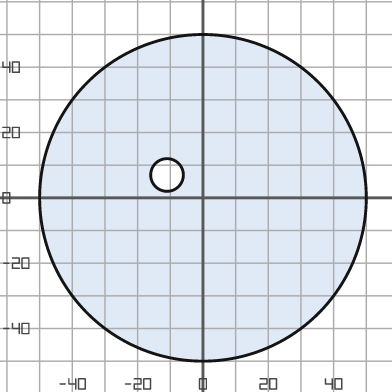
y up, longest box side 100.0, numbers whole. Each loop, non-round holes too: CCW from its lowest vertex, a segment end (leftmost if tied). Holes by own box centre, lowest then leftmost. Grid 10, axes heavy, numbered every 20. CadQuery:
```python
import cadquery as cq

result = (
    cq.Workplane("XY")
    .moveTo(0.0, 0.0)
    .circle(50.0)
    .moveTo(-11.0, 7.0)
    .circle(5.0)
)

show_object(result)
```